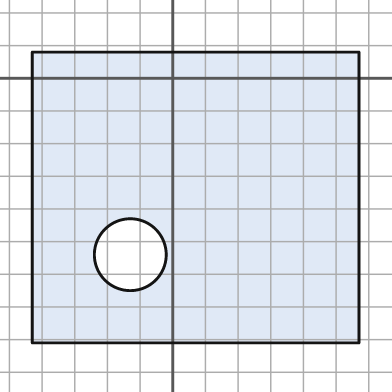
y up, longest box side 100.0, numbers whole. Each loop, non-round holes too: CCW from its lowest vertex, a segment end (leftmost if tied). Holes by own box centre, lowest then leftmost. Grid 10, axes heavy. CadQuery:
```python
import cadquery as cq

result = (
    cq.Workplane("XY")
    .moveTo(-43.0, -81.0)
    .lineTo(57.0, -81.0)
    .lineTo(57.0, 8.0)
    .lineTo(-43.0, 8.0)
    .close()
    .moveTo(-13.0, -54.0)
    .circle(11.0)
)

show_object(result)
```